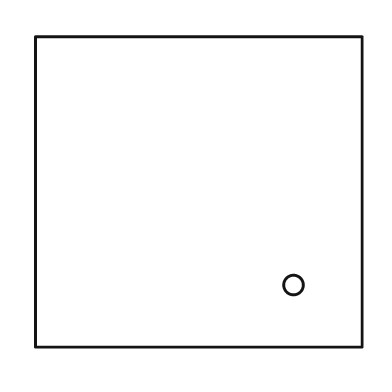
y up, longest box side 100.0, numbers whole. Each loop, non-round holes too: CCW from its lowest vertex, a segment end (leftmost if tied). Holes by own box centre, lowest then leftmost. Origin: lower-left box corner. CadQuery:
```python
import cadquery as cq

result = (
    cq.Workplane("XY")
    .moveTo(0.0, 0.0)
    .lineTo(100.0, 0.0)
    .lineTo(100.0, 95.0)
    .lineTo(0.0, 95.0)
    .close()
    .moveTo(79.0, 19.0)
    .circle(3.0)
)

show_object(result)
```